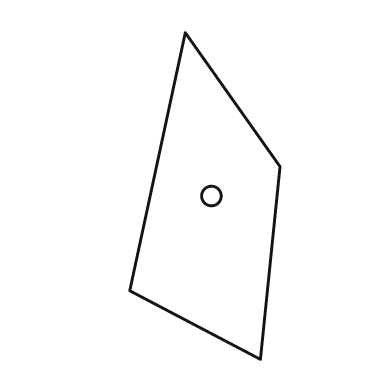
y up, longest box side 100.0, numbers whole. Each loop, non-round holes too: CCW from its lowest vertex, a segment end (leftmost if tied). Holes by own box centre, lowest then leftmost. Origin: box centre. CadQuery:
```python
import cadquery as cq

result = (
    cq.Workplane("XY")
    .moveTo(17.0, -50.0)
    .lineTo(23.0, 9.0)
    .lineTo(-6.0, 50.0)
    .lineTo(-23.0, -29.0)
    .close()
    .moveTo(2.0, 0.0)
    .circle(3.0)
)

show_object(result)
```